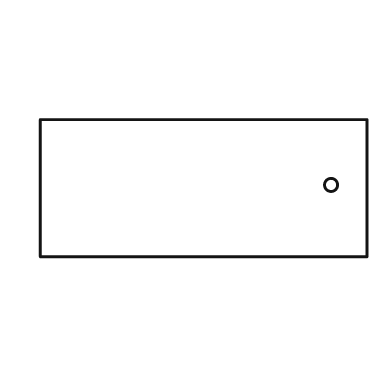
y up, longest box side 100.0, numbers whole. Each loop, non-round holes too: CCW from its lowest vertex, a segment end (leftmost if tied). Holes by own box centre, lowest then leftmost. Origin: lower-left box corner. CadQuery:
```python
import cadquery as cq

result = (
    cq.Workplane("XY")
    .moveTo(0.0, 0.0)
    .lineTo(100.0, 0.0)
    .lineTo(100.0, 42.0)
    .lineTo(0.0, 42.0)
    .close()
    .moveTo(89.0, 22.0)
    .circle(2.0)
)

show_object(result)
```